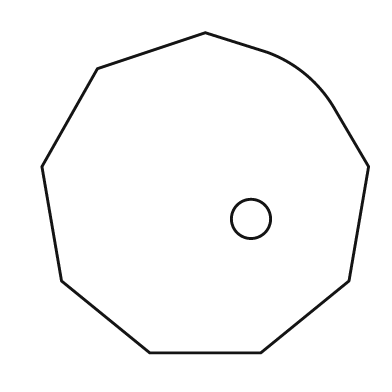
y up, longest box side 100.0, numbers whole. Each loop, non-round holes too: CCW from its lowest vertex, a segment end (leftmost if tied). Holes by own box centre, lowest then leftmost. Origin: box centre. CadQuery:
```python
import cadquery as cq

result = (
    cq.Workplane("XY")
    .moveTo(-17.0, -49.0)
    .lineTo(17.0, -49.0)
    .lineTo(44.0, -27.0)
    .lineTo(50.0, 8.0)
    .lineTo(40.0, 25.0)
    .threePointArc((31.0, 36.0), (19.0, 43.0))
    .lineTo(0.0, 49.0)
    .lineTo(-33.0, 38.0)
    .lineTo(-50.0, 8.0)
    .lineTo(-44.0, -27.0)
    .close()
    .moveTo(14.0, -8.0)
    .circle(6.0)
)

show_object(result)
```